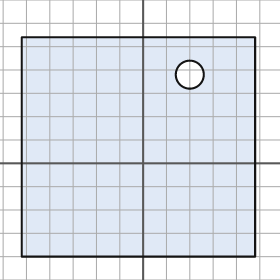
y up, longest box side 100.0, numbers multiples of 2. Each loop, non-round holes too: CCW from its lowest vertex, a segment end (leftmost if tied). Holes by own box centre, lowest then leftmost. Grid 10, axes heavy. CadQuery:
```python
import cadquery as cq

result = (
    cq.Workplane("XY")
    .moveTo(-52.0, -40.0)
    .lineTo(48.0, -40.0)
    .lineTo(48.0, 54.0)
    .lineTo(-52.0, 54.0)
    .close()
    .moveTo(20.0, 38.0)
    .circle(6.0)
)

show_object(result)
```